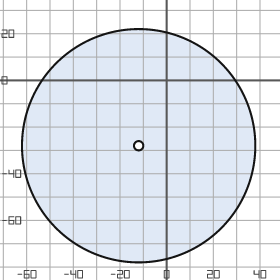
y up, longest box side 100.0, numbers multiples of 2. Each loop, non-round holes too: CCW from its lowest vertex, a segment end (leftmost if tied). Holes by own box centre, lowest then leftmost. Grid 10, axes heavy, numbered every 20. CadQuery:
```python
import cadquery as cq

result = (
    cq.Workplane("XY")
    .moveTo(-12.0, -28.0)
    .circle(50.0)
    .moveTo(-12.0, -28.0)
    .circle(2.0)
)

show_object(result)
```